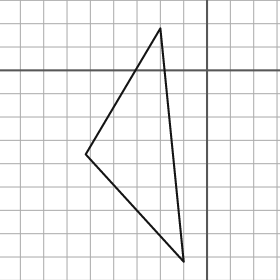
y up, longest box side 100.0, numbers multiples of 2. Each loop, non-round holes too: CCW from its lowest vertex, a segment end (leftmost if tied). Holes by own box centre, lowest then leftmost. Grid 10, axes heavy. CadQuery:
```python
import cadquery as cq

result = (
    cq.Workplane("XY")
    .moveTo(-10.0, -82.0)
    .lineTo(-20.0, 18.0)
    .lineTo(-52.0, -36.0)
    .close()
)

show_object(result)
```